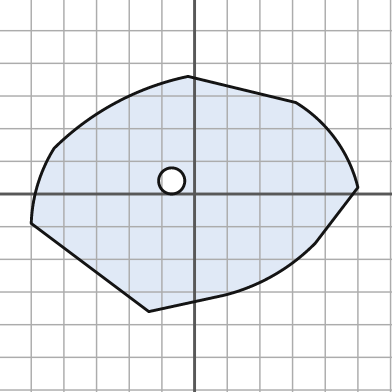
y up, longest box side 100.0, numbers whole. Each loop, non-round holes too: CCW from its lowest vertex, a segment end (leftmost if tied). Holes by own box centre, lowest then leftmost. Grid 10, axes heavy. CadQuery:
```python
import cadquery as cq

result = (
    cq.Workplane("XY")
    .moveTo(-14.0, -36.0)
    .lineTo(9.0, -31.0)
    .threePointArc((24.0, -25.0), (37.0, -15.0))
    .lineTo(50.0, 2.0)
    .threePointArc((43.0, 17.0), (31.0, 28.0))
    .lineTo(-2.0, 36.0)
    .threePointArc((-24.0, 28.0), (-43.0, 14.0))
    .threePointArc((-48.0, 3.0), (-50.0, -9.0))
    .close()
    .moveTo(-7.0, 4.0)
    .circle(4.0)
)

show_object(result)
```